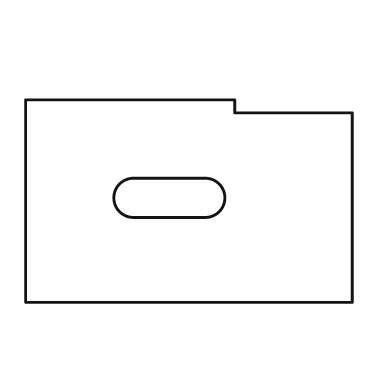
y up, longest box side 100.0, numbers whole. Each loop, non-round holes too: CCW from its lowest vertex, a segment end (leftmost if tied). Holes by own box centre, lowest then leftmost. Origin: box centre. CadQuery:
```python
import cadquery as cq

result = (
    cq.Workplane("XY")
    .moveTo(-50.0, -31.0)
    .lineTo(50.0, -31.0)
    .lineTo(50.0, 27.0)
    .lineTo(14.0, 27.0)
    .lineTo(14.0, 31.0)
    .lineTo(-50.0, 31.0)
    .close()
    .moveTo(-17.0, -5.0)
    .lineTo(5.0, -5.0)
    .threePointArc((11.0, 1.0), (5.0, 7.0))
    .lineTo(-17.0, 7.0)
    .threePointArc((-23.0, 1.0), (-17.0, -5.0))
    .close()
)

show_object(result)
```